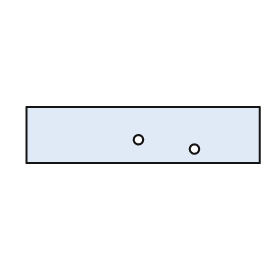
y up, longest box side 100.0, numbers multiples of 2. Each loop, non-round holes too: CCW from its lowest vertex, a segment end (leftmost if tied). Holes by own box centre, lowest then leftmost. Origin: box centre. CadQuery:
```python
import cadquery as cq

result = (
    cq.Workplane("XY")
    .moveTo(-50.0, -12.0)
    .lineTo(50.0, -12.0)
    .lineTo(50.0, 12.0)
    .lineTo(-50.0, 12.0)
    .close()
    .moveTo(22.0, -6.0)
    .circle(2.0)
    .moveTo(-2.0, -2.0)
    .circle(2.0)
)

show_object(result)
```